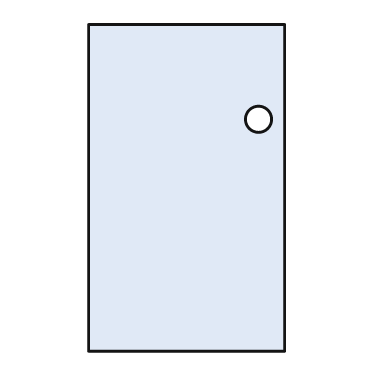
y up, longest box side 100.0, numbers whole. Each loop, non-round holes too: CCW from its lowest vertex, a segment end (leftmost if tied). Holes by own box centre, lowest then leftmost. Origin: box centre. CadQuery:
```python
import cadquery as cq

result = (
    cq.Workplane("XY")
    .moveTo(-30.0, -50.0)
    .lineTo(30.0, -50.0)
    .lineTo(30.0, 50.0)
    .lineTo(-30.0, 50.0)
    .close()
    .moveTo(22.0, 21.0)
    .circle(4.0)
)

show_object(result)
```